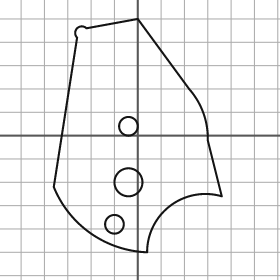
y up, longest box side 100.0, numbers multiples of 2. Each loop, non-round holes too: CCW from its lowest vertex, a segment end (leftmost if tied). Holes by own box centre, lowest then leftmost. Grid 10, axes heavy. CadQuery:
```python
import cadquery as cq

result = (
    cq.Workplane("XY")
    .moveTo(4.0, -50.0)
    .threePointArc((14.0, -30.0), (36.0, -26.0))
    .lineTo(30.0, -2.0)
    .threePointArc((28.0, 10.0), (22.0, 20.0))
    .lineTo(0.0, 50.0)
    .lineTo(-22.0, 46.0)
    .threePointArc((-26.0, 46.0), (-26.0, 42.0))
    .lineTo(-36.0, -22.0)
    .threePointArc((-20.0, -42.0), (4.0, -50.0))
    .close()
    .moveTo(-10.0, -38.0)
    .circle(4.0)
    .moveTo(-4.0, -20.0)
    .circle(6.0)
    .moveTo(-4.0, 4.0)
    .circle(4.0)
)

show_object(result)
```